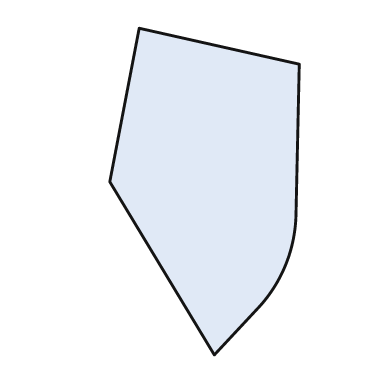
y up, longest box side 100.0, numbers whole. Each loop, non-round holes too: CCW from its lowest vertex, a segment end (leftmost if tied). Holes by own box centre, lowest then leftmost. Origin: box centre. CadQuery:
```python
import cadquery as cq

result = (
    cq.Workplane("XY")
    .moveTo(3.0, -50.0)
    .lineTo(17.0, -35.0)
    .threePointArc((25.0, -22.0), (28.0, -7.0))
    .lineTo(29.0, 39.0)
    .lineTo(-20.0, 50.0)
    .lineTo(-29.0, 3.0)
    .close()
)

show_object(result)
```